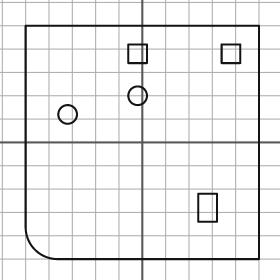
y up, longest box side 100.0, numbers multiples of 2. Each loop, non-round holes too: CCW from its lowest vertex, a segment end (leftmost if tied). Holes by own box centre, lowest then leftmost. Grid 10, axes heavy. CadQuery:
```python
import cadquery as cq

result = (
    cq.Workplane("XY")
    .moveTo(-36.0, -50.0)
    .lineTo(50.0, -50.0)
    .lineTo(50.0, 50.0)
    .lineTo(-50.0, 50.0)
    .lineTo(-50.0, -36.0)
    .threePointArc((-46.0, -46.0), (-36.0, -50.0))
    .close()
    .moveTo(24.0, -34.0)
    .lineTo(32.0, -34.0)
    .lineTo(32.0, -22.0)
    .lineTo(24.0, -22.0)
    .close()
    .moveTo(-32.0, 12.0)
    .circle(4.0)
    .moveTo(-2.0, 20.0)
    .circle(4.0)
    .moveTo(-6.0, 34.0)
    .lineTo(2.0, 34.0)
    .lineTo(2.0, 42.0)
    .lineTo(-6.0, 42.0)
    .close()
    .moveTo(34.0, 34.0)
    .lineTo(42.0, 34.0)
    .lineTo(42.0, 42.0)
    .lineTo(34.0, 42.0)
    .close()
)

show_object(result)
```